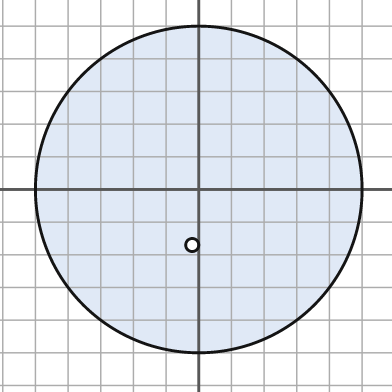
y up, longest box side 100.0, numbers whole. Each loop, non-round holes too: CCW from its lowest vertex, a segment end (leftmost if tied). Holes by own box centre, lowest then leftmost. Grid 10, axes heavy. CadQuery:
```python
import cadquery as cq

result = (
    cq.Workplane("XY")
    .moveTo(0.0, 0.0)
    .circle(50.0)
    .moveTo(-2.0, -17.0)
    .circle(2.0)
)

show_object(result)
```